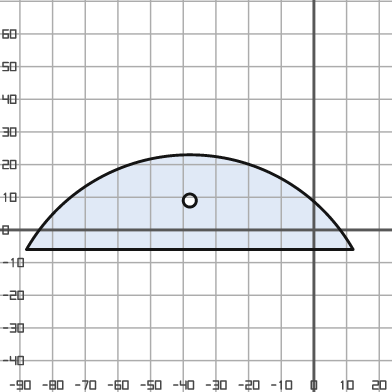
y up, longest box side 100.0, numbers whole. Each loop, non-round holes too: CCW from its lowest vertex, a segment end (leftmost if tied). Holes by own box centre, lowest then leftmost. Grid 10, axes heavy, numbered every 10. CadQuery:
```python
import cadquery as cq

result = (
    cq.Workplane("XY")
    .moveTo(-88.0, -6.0)
    .lineTo(12.0, -6.0)
    .threePointArc((-38.0, 23.0), (-88.0, -6.0))
    .close()
    .moveTo(-38.0, 9.0)
    .circle(2.0)
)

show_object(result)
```